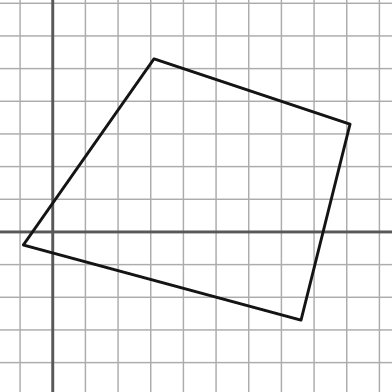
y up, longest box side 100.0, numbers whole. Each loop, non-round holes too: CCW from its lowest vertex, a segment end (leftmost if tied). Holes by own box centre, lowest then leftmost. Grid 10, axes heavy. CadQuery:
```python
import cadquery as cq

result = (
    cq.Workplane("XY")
    .moveTo(76.0, -27.0)
    .lineTo(91.0, 33.0)
    .lineTo(31.0, 53.0)
    .lineTo(-9.0, -4.0)
    .close()
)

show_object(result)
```